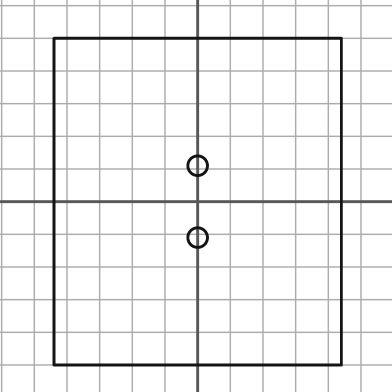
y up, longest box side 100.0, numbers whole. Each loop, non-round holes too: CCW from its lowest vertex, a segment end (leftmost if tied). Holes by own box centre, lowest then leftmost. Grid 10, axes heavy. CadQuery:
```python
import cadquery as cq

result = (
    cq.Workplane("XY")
    .moveTo(-44.0, -50.0)
    .lineTo(44.0, -50.0)
    .lineTo(44.0, 50.0)
    .lineTo(-44.0, 50.0)
    .close()
    .moveTo(0.0, -11.0)
    .circle(3.0)
    .moveTo(0.0, 11.0)
    .circle(3.0)
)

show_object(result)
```